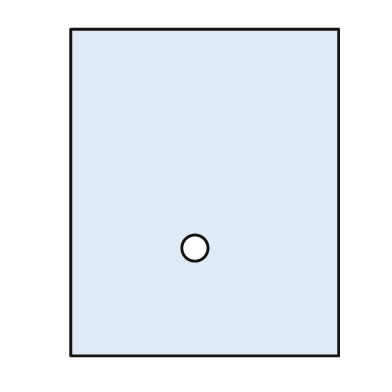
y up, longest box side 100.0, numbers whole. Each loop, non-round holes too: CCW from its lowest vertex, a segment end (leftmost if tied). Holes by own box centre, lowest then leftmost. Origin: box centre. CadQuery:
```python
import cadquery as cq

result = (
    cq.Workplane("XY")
    .moveTo(-41.0, -50.0)
    .lineTo(41.0, -50.0)
    .lineTo(41.0, 50.0)
    .lineTo(-41.0, 50.0)
    .close()
    .moveTo(-3.0, -17.0)
    .circle(4.0)
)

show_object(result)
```